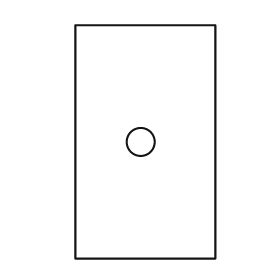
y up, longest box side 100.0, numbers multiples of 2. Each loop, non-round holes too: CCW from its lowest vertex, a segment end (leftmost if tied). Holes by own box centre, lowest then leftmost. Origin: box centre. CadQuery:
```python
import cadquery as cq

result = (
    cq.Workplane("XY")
    .moveTo(-30.0, -50.0)
    .lineTo(30.0, -50.0)
    .lineTo(30.0, 50.0)
    .lineTo(-30.0, 50.0)
    .close()
    .moveTo(-2.0, 0.0)
    .circle(6.0)
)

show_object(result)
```